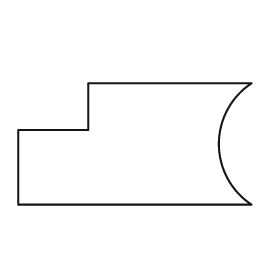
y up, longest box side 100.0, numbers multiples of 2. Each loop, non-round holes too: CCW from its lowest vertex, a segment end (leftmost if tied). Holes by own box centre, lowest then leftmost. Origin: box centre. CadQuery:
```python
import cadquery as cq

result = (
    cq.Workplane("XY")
    .moveTo(-50.0, -26.0)
    .lineTo(50.0, -26.0)
    .threePointArc((36.0, 0.0), (50.0, 26.0))
    .lineTo(-20.0, 26.0)
    .lineTo(-20.0, 6.0)
    .lineTo(-50.0, 6.0)
    .close()
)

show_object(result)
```